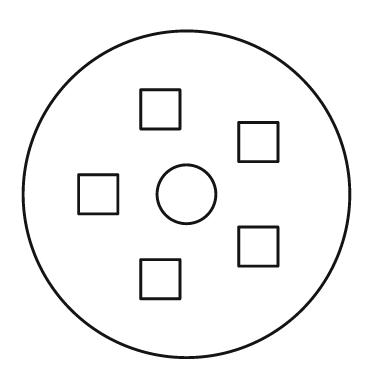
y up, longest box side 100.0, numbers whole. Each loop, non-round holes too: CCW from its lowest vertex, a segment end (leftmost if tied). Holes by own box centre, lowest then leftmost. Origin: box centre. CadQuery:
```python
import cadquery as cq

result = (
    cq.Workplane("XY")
    .moveTo(0.0, 0.0)
    .circle(50.0)
    .moveTo(-14.0, -32.0)
    .lineTo(-2.0, -32.0)
    .lineTo(-2.0, -20.0)
    .lineTo(-14.0, -20.0)
    .close()
    .moveTo(16.0, -22.0)
    .lineTo(28.0, -22.0)
    .lineTo(28.0, -10.0)
    .lineTo(16.0, -10.0)
    .close()
    .moveTo(-33.0, -6.0)
    .lineTo(-21.0, -6.0)
    .lineTo(-21.0, 6.0)
    .lineTo(-33.0, 6.0)
    .close()
    .moveTo(0.0, 0.0)
    .circle(9.0)
    .moveTo(16.0, 10.0)
    .lineTo(28.0, 10.0)
    .lineTo(28.0, 22.0)
    .lineTo(16.0, 22.0)
    .close()
    .moveTo(-14.0, 20.0)
    .lineTo(-2.0, 20.0)
    .lineTo(-2.0, 32.0)
    .lineTo(-14.0, 32.0)
    .close()
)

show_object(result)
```